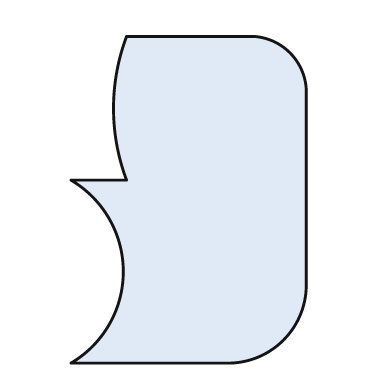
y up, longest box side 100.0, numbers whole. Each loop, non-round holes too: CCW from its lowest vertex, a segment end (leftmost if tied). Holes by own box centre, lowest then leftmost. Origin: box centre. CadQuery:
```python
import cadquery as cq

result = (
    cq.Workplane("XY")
    .moveTo(-36.0, -50.0)
    .lineTo(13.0, -50.0)
    .threePointArc((29.0, -43.0), (36.0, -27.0))
    .lineTo(36.0, 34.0)
    .threePointArc((31.0, 45.0), (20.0, 50.0))
    .lineTo(-19.0, 50.0)
    .threePointArc((-23.0, 28.0), (-19.0, 6.0))
    .lineTo(-36.0, 6.0)
    .threePointArc((-20.0, -22.0), (-36.0, -50.0))
    .close()
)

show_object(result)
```